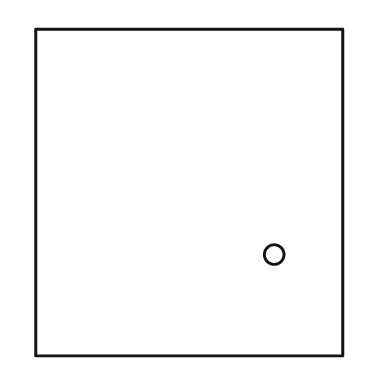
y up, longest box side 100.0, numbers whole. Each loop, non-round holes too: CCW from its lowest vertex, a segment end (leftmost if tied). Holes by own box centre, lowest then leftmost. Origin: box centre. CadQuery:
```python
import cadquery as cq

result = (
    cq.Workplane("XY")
    .moveTo(-47.0, -50.0)
    .lineTo(47.0, -50.0)
    .lineTo(47.0, 50.0)
    .lineTo(-47.0, 50.0)
    .close()
    .moveTo(26.0, -19.0)
    .circle(3.0)
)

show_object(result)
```